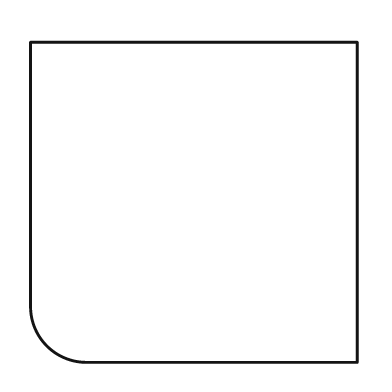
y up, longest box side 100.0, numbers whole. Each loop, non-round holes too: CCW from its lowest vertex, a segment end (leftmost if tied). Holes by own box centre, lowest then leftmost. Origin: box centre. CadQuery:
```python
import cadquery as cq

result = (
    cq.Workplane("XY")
    .moveTo(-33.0, -49.0)
    .lineTo(50.0, -49.0)
    .lineTo(50.0, 49.0)
    .lineTo(-50.0, 49.0)
    .lineTo(-50.0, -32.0)
    .threePointArc((-45.0, -44.0), (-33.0, -49.0))
    .close()
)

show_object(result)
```